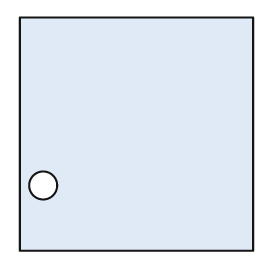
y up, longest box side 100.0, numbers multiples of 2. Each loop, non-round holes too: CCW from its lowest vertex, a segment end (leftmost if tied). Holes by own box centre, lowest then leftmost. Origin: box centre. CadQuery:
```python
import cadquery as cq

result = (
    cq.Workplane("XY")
    .moveTo(-50.0, -50.0)
    .lineTo(50.0, -50.0)
    .lineTo(50.0, 50.0)
    .lineTo(-50.0, 50.0)
    .close()
    .moveTo(-40.0, -22.0)
    .circle(6.0)
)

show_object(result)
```